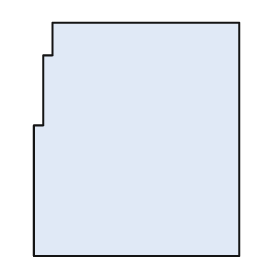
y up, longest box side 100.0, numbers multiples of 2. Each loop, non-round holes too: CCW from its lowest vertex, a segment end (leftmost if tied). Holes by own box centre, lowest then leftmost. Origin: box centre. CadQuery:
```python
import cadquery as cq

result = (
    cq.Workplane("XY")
    .moveTo(-44.0, -50.0)
    .lineTo(44.0, -50.0)
    .lineTo(44.0, 50.0)
    .lineTo(-36.0, 50.0)
    .lineTo(-36.0, 36.0)
    .lineTo(-40.0, 36.0)
    .lineTo(-40.0, 6.0)
    .lineTo(-44.0, 6.0)
    .close()
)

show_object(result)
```